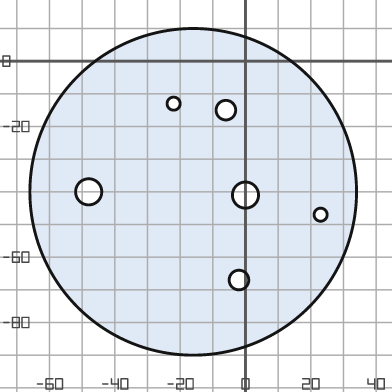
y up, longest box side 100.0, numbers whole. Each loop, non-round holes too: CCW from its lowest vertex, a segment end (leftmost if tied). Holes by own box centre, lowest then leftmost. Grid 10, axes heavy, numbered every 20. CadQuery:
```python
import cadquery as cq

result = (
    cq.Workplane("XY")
    .moveTo(-16.0, -40.0)
    .circle(50.0)
    .moveTo(-2.0, -67.0)
    .circle(3.0)
    .moveTo(23.0, -47.0)
    .circle(2.0)
    .moveTo(0.0, -41.0)
    .circle(4.0)
    .moveTo(-48.0, -40.0)
    .circle(4.0)
    .moveTo(-6.0, -15.0)
    .circle(3.0)
    .moveTo(-22.0, -13.0)
    .circle(2.0)
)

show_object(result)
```